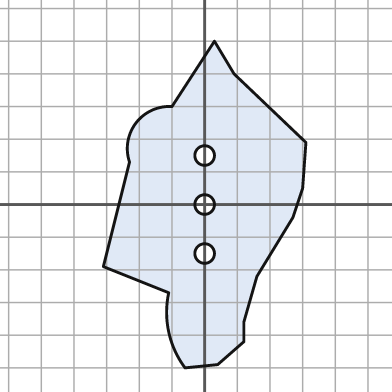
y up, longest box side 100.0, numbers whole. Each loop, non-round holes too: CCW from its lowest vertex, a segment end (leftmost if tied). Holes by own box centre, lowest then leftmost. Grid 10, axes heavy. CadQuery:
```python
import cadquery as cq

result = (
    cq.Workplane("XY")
    .moveTo(-6.0, -50.0)
    .lineTo(4.0, -49.0)
    .lineTo(12.0, -42.0)
    .lineTo(12.0, -36.0)
    .lineTo(16.0, -22.0)
    .lineTo(27.0, -4.0)
    .lineTo(30.0, 5.0)
    .lineTo(31.0, 19.0)
    .lineTo(9.0, 40.0)
    .lineTo(3.0, 50.0)
    .lineTo(-10.0, 30.0)
    .threePointArc((-21.0, 25.0), (-23.0, 13.0))
    .lineTo(-31.0, -19.0)
    .lineTo(-11.0, -27.0)
    .threePointArc((-11.0, -39.0), (-6.0, -50.0))
    .close()
    .moveTo(0.0, -15.0)
    .circle(3.0)
    .moveTo(0.0, 0.0)
    .circle(3.0)
    .moveTo(0.0, 15.0)
    .circle(3.0)
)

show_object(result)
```